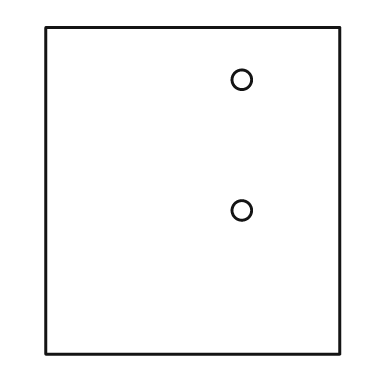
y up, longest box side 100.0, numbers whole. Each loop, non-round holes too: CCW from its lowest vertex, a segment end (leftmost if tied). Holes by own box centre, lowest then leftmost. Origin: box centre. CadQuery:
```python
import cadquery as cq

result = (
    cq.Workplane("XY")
    .moveTo(-45.0, -50.0)
    .lineTo(45.0, -50.0)
    .lineTo(45.0, 50.0)
    .lineTo(-45.0, 50.0)
    .close()
    .moveTo(15.0, -6.0)
    .circle(3.0)
    .moveTo(15.0, 34.0)
    .circle(3.0)
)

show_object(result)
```